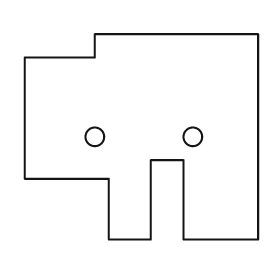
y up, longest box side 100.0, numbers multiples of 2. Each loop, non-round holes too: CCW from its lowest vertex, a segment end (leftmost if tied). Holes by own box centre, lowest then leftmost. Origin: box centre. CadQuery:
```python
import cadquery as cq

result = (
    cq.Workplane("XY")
    .moveTo(-14.0, -44.0)
    .lineTo(4.0, -44.0)
    .lineTo(4.0, -10.0)
    .lineTo(18.0, -10.0)
    .lineTo(18.0, -44.0)
    .lineTo(50.0, -44.0)
    .lineTo(50.0, 44.0)
    .lineTo(-20.0, 44.0)
    .lineTo(-20.0, 34.0)
    .lineTo(-50.0, 34.0)
    .lineTo(-50.0, -18.0)
    .lineTo(-14.0, -18.0)
    .close()
    .moveTo(-20.0, 0.0)
    .circle(4.0)
    .moveTo(22.0, 0.0)
    .circle(4.0)
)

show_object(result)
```